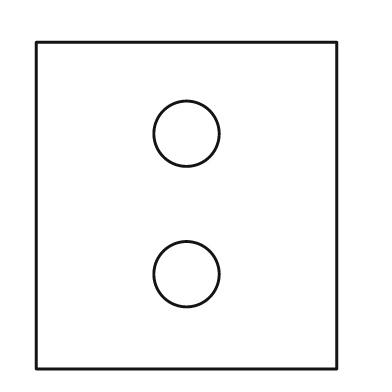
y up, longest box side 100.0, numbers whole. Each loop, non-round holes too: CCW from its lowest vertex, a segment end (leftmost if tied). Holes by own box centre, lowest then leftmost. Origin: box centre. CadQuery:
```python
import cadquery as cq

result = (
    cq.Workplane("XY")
    .moveTo(-46.0, -50.0)
    .lineTo(46.0, -50.0)
    .lineTo(46.0, 50.0)
    .lineTo(-46.0, 50.0)
    .close()
    .moveTo(0.0, -21.0)
    .circle(10.0)
    .moveTo(0.0, 22.0)
    .circle(10.0)
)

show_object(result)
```